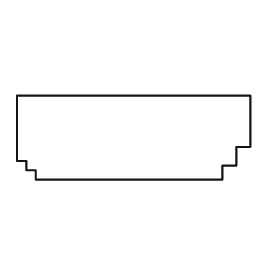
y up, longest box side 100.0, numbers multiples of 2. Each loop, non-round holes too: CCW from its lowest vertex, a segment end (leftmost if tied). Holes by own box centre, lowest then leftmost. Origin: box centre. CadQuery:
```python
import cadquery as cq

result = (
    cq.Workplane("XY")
    .moveTo(-42.0, -18.0)
    .lineTo(38.0, -18.0)
    .lineTo(38.0, -12.0)
    .lineTo(44.0, -12.0)
    .lineTo(44.0, -4.0)
    .lineTo(50.0, -4.0)
    .lineTo(50.0, 18.0)
    .lineTo(-50.0, 18.0)
    .lineTo(-50.0, -10.0)
    .lineTo(-46.0, -10.0)
    .lineTo(-46.0, -14.0)
    .lineTo(-42.0, -14.0)
    .close()
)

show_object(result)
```